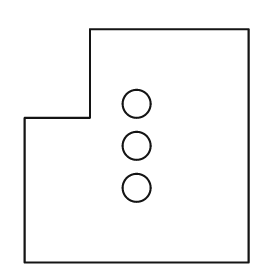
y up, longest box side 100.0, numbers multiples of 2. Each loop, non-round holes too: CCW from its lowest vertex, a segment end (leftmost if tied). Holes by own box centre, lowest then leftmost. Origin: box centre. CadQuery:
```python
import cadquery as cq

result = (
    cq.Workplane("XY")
    .moveTo(-48.0, -50.0)
    .lineTo(48.0, -50.0)
    .lineTo(48.0, 50.0)
    .lineTo(-20.0, 50.0)
    .lineTo(-20.0, 12.0)
    .lineTo(-48.0, 12.0)
    .close()
    .moveTo(0.0, -18.0)
    .circle(6.0)
    .moveTo(0.0, 0.0)
    .circle(6.0)
    .moveTo(0.0, 18.0)
    .circle(6.0)
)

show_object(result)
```